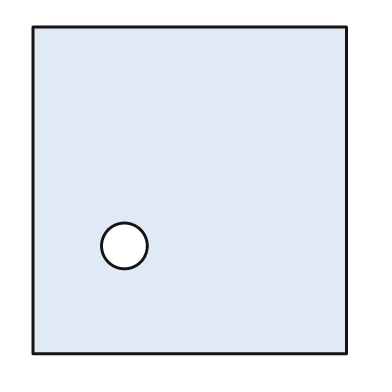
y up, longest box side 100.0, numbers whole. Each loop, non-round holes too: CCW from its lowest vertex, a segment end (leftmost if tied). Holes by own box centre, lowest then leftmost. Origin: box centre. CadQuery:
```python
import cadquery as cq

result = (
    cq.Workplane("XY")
    .moveTo(-48.0, -50.0)
    .lineTo(48.0, -50.0)
    .lineTo(48.0, 50.0)
    .lineTo(-48.0, 50.0)
    .close()
    .moveTo(-20.0, -17.0)
    .circle(7.0)
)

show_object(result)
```